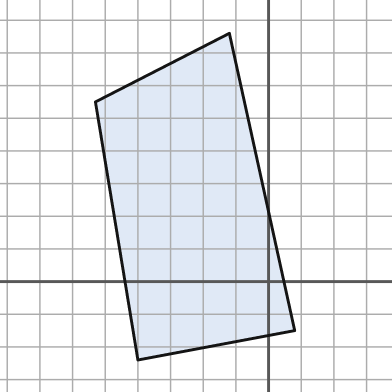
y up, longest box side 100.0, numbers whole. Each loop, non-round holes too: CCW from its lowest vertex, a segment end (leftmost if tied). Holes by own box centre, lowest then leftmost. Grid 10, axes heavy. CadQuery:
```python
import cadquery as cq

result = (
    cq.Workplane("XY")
    .moveTo(-40.0, -24.0)
    .lineTo(8.0, -15.0)
    .lineTo(-12.0, 76.0)
    .lineTo(-53.0, 55.0)
    .close()
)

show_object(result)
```